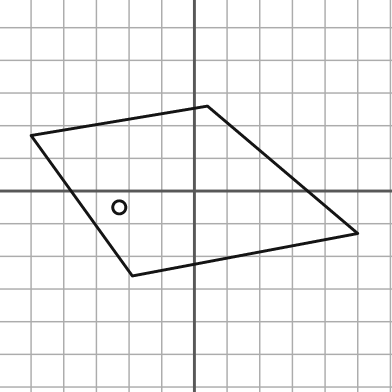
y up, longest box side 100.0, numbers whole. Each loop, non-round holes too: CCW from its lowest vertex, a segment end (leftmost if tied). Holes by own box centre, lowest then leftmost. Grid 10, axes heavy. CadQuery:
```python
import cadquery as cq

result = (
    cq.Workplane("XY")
    .moveTo(-19.0, -26.0)
    .lineTo(50.0, -13.0)
    .lineTo(4.0, 26.0)
    .lineTo(-50.0, 17.0)
    .close()
    .moveTo(-23.0, -5.0)
    .circle(2.0)
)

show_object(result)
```